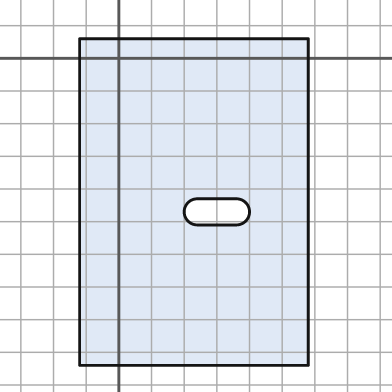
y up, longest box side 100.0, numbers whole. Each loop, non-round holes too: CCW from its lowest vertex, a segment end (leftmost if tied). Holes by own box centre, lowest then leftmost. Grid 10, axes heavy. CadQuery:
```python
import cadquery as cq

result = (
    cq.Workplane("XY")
    .moveTo(-12.0, -94.0)
    .lineTo(58.0, -94.0)
    .lineTo(58.0, 6.0)
    .lineTo(-12.0, 6.0)
    .close()
    .moveTo(24.0, -51.0)
    .lineTo(36.0, -51.0)
    .threePointArc((40.0, -47.0), (36.0, -43.0))
    .lineTo(24.0, -43.0)
    .threePointArc((20.0, -47.0), (24.0, -51.0))
    .close()
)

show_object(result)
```